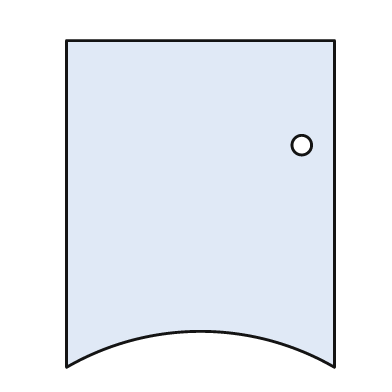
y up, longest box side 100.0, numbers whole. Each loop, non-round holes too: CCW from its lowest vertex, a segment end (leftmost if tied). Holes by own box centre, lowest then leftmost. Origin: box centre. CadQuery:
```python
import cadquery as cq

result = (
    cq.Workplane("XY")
    .moveTo(-41.0, -50.0)
    .threePointArc((0.0, -39.0), (41.0, -50.0))
    .lineTo(41.0, 50.0)
    .lineTo(-41.0, 50.0)
    .close()
    .moveTo(31.0, 18.0)
    .circle(3.0)
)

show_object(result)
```